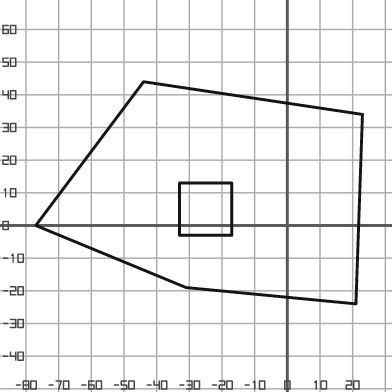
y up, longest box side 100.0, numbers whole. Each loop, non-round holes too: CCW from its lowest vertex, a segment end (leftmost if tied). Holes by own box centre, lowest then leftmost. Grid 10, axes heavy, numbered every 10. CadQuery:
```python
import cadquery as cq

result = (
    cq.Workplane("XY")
    .moveTo(21.0, -24.0)
    .lineTo(23.0, 34.0)
    .lineTo(-44.0, 44.0)
    .lineTo(-77.0, 0.0)
    .lineTo(-31.0, -19.0)
    .close()
    .moveTo(-33.0, -3.0)
    .lineTo(-17.0, -3.0)
    .lineTo(-17.0, 13.0)
    .lineTo(-33.0, 13.0)
    .close()
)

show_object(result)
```